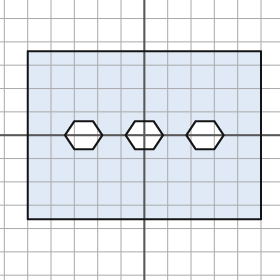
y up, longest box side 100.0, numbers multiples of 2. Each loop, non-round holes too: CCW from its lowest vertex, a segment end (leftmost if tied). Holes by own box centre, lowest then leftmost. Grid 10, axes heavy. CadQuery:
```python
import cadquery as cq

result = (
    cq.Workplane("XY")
    .moveTo(-50.0, -36.0)
    .lineTo(50.0, -36.0)
    .lineTo(50.0, 36.0)
    .lineTo(-50.0, 36.0)
    .close()
    .moveTo(-30.0, -6.0)
    .lineTo(-22.0, -6.0)
    .lineTo(-18.0, 0.0)
    .lineTo(-22.0, 6.0)
    .lineTo(-30.0, 6.0)
    .lineTo(-34.0, 0.0)
    .close()
    .moveTo(-4.0, -6.0)
    .lineTo(4.0, -6.0)
    .lineTo(8.0, 0.0)
    .lineTo(4.0, 6.0)
    .lineTo(-4.0, 6.0)
    .lineTo(-8.0, 0.0)
    .close()
    .moveTo(22.0, -6.0)
    .lineTo(30.0, -6.0)
    .lineTo(34.0, 0.0)
    .lineTo(30.0, 6.0)
    .lineTo(22.0, 6.0)
    .lineTo(18.0, 0.0)
    .close()
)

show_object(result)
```